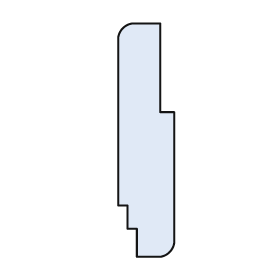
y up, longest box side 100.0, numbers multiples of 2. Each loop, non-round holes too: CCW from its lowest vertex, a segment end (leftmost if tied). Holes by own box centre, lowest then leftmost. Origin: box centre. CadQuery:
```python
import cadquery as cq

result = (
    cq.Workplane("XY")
    .moveTo(-4.0, -50.0)
    .lineTo(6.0, -50.0)
    .threePointArc((10.0, -48.0), (12.0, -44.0))
    .lineTo(12.0, 12.0)
    .lineTo(6.0, 12.0)
    .lineTo(6.0, 50.0)
    .lineTo(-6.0, 50.0)
    .threePointArc((-10.0, 48.0), (-12.0, 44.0))
    .lineTo(-12.0, -28.0)
    .lineTo(-8.0, -28.0)
    .lineTo(-8.0, -38.0)
    .lineTo(-4.0, -38.0)
    .close()
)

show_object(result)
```